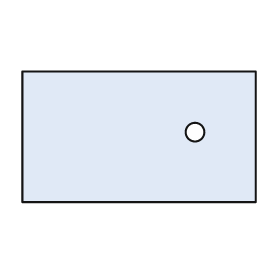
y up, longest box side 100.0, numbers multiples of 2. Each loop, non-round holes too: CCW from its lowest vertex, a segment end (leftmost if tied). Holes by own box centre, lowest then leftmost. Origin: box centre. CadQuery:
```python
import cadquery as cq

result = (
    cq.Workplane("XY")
    .moveTo(-50.0, -28.0)
    .lineTo(50.0, -28.0)
    .lineTo(50.0, 28.0)
    .lineTo(-50.0, 28.0)
    .close()
    .moveTo(24.0, 2.0)
    .circle(4.0)
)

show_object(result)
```